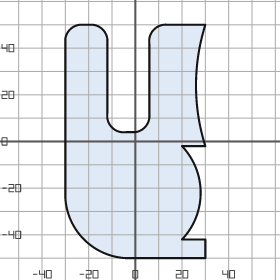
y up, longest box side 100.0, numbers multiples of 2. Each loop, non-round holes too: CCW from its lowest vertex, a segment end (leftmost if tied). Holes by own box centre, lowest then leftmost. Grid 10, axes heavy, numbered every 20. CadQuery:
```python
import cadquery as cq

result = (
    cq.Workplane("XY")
    .moveTo(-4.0, -50.0)
    .lineTo(30.0, -50.0)
    .lineTo(30.0, -42.0)
    .lineTo(20.0, -42.0)
    .threePointArc((28.0, -22.0), (20.0, -2.0))
    .lineTo(30.0, -2.0)
    .threePointArc((26.0, 24.0), (30.0, 50.0))
    .lineTo(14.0, 50.0)
    .threePointArc((8.0, 48.0), (6.0, 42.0))
    .lineTo(6.0, 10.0)
    .threePointArc((4.0, 6.0), (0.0, 4.0))
    .lineTo(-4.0, 4.0)
    .threePointArc((-10.0, 6.0), (-12.0, 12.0))
    .lineTo(-12.0, 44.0)
    .threePointArc((-14.0, 48.0), (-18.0, 50.0))
    .lineTo(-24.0, 50.0)
    .threePointArc((-28.0, 48.0), (-30.0, 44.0))
    .lineTo(-30.0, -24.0)
    .threePointArc((-22.0, -42.0), (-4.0, -50.0))
    .close()
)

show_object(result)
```